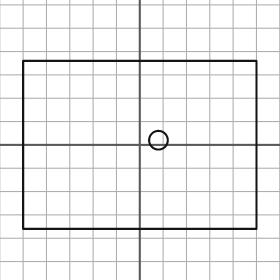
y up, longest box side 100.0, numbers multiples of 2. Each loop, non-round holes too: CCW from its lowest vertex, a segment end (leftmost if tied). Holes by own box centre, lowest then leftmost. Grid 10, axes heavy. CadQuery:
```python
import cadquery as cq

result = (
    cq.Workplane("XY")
    .moveTo(-50.0, -36.0)
    .lineTo(50.0, -36.0)
    .lineTo(50.0, 36.0)
    .lineTo(-50.0, 36.0)
    .close()
    .moveTo(8.0, 2.0)
    .circle(4.0)
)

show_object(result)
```